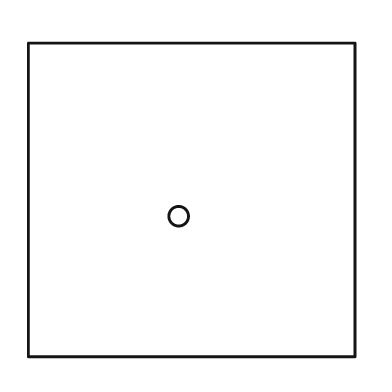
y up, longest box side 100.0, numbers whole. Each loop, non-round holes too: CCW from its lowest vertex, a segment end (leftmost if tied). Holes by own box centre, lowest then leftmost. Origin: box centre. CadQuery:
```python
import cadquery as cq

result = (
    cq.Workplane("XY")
    .moveTo(-50.0, -48.0)
    .lineTo(50.0, -48.0)
    .lineTo(50.0, 48.0)
    .lineTo(-50.0, 48.0)
    .close()
    .moveTo(-4.0, -5.0)
    .circle(3.0)
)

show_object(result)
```